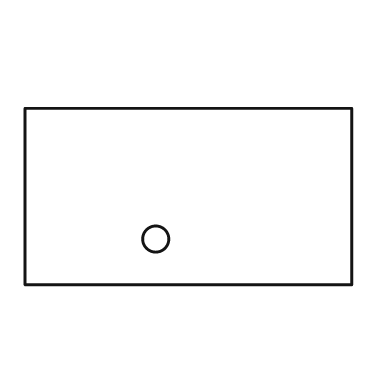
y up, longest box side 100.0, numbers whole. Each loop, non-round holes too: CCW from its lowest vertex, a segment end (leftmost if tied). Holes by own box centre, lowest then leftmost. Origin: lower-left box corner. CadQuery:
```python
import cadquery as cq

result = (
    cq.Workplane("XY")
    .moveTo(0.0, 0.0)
    .lineTo(100.0, 0.0)
    .lineTo(100.0, 54.0)
    .lineTo(0.0, 54.0)
    .close()
    .moveTo(40.0, 14.0)
    .circle(4.0)
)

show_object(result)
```